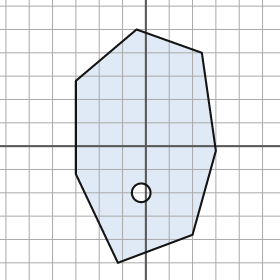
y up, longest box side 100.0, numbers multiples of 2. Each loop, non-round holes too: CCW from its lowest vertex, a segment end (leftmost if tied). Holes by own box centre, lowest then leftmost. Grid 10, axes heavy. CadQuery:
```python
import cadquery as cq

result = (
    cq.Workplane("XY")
    .moveTo(-12.0, -50.0)
    .lineTo(20.0, -38.0)
    .lineTo(30.0, -2.0)
    .lineTo(24.0, 40.0)
    .lineTo(-4.0, 50.0)
    .lineTo(-30.0, 28.0)
    .lineTo(-30.0, -12.0)
    .close()
    .moveTo(-2.0, -20.0)
    .circle(4.0)
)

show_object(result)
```